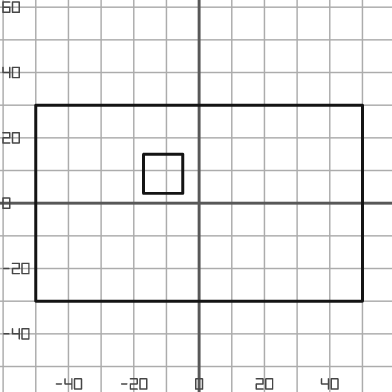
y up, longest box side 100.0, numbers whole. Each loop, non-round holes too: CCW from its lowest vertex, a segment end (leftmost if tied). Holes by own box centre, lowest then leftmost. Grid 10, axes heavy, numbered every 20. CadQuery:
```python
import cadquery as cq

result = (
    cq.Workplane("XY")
    .moveTo(-50.0, -30.0)
    .lineTo(50.0, -30.0)
    .lineTo(50.0, 30.0)
    .lineTo(-50.0, 30.0)
    .close()
    .moveTo(-17.0, 3.0)
    .lineTo(-5.0, 3.0)
    .lineTo(-5.0, 15.0)
    .lineTo(-17.0, 15.0)
    .close()
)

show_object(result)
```